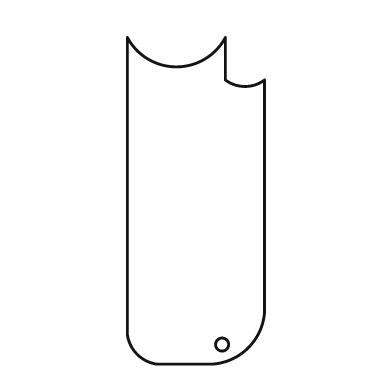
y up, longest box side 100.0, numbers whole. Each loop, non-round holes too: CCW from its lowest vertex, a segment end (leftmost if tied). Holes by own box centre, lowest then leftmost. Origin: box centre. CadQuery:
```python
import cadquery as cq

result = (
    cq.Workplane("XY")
    .moveTo(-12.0, -50.0)
    .lineTo(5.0, -50.0)
    .threePointArc((16.0, -45.0), (21.0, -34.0))
    .lineTo(21.0, 37.0)
    .threePointArc((15.0, 35.0), (9.0, 37.0))
    .lineTo(9.0, 50.0)
    .threePointArc((-6.0, 41.0), (-21.0, 50.0))
    .lineTo(-21.0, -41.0)
    .threePointArc((-18.0, -47.0), (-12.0, -50.0))
    .close()
    .moveTo(8.0, -44.0)
    .circle(2.0)
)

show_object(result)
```